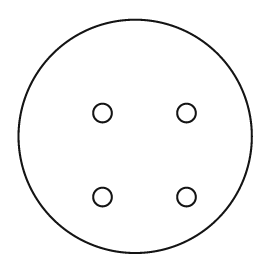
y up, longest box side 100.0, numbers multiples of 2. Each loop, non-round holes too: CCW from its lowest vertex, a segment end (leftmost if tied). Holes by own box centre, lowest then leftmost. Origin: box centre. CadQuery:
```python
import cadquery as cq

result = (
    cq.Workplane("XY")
    .moveTo(0.0, 0.0)
    .circle(50.0)
    .moveTo(-14.0, -26.0)
    .circle(4.0)
    .moveTo(22.0, -26.0)
    .circle(4.0)
    .moveTo(-14.0, 10.0)
    .circle(4.0)
    .moveTo(22.0, 10.0)
    .circle(4.0)
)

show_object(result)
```